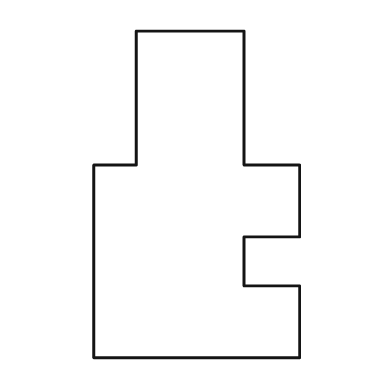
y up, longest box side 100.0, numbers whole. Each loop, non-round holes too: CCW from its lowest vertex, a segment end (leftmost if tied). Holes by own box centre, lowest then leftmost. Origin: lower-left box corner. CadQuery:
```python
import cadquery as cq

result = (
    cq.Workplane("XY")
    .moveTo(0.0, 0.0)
    .lineTo(63.0, 0.0)
    .lineTo(63.0, 22.0)
    .lineTo(46.0, 22.0)
    .lineTo(46.0, 37.0)
    .lineTo(63.0, 37.0)
    .lineTo(63.0, 59.0)
    .lineTo(46.0, 59.0)
    .lineTo(46.0, 100.0)
    .lineTo(13.0, 100.0)
    .lineTo(13.0, 59.0)
    .lineTo(0.0, 59.0)
    .close()
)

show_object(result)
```